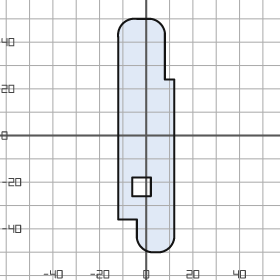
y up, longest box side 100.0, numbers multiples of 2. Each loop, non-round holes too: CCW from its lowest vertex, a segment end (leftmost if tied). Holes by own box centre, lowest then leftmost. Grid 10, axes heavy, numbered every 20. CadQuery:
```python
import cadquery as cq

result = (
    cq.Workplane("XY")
    .moveTo(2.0, -50.0)
    .lineTo(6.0, -50.0)
    .threePointArc((10.0, -48.0), (12.0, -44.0))
    .lineTo(12.0, 24.0)
    .lineTo(8.0, 24.0)
    .lineTo(8.0, 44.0)
    .threePointArc((6.0, 48.0), (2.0, 50.0))
    .lineTo(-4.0, 50.0)
    .threePointArc((-10.0, 48.0), (-12.0, 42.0))
    .lineTo(-12.0, -36.0)
    .lineTo(-4.0, -36.0)
    .lineTo(-4.0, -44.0)
    .threePointArc((-2.0, -48.0), (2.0, -50.0))
    .close()
    .moveTo(-6.0, -26.0)
    .lineTo(2.0, -26.0)
    .lineTo(2.0, -18.0)
    .lineTo(-6.0, -18.0)
    .close()
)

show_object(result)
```